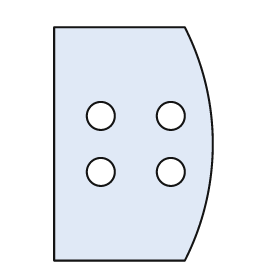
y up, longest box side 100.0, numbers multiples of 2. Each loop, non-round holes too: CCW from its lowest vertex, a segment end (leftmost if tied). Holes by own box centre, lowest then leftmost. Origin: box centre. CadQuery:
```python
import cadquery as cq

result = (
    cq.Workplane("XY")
    .moveTo(-34.0, -50.0)
    .lineTo(22.0, -50.0)
    .threePointArc((34.0, 0.0), (22.0, 50.0))
    .lineTo(-34.0, 50.0)
    .close()
    .moveTo(-14.0, -12.0)
    .circle(6.0)
    .moveTo(16.0, -12.0)
    .circle(6.0)
    .moveTo(-14.0, 12.0)
    .circle(6.0)
    .moveTo(16.0, 12.0)
    .circle(6.0)
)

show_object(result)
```